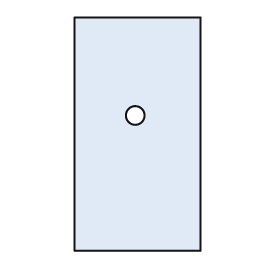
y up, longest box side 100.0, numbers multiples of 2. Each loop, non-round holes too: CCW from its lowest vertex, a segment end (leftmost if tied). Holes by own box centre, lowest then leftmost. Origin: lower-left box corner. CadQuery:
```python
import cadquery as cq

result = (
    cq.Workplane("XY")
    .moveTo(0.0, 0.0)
    .lineTo(54.0, 0.0)
    .lineTo(54.0, 100.0)
    .lineTo(0.0, 100.0)
    .close()
    .moveTo(26.0, 58.0)
    .circle(4.0)
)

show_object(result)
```